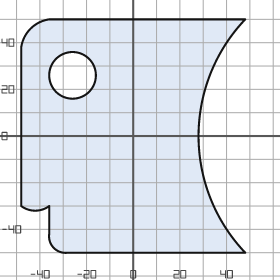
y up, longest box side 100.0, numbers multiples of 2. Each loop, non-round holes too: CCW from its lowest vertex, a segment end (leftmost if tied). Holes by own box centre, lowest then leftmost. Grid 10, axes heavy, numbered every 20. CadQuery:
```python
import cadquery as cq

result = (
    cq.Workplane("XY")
    .moveTo(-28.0, -50.0)
    .lineTo(48.0, -50.0)
    .threePointArc((28.0, 0.0), (48.0, 50.0))
    .lineTo(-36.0, 50.0)
    .threePointArc((-44.0, 46.0), (-48.0, 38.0))
    .lineTo(-48.0, -30.0)
    .threePointArc((-42.0, -32.0), (-36.0, -30.0))
    .lineTo(-36.0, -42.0)
    .threePointArc((-34.0, -48.0), (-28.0, -50.0))
    .close()
    .moveTo(-26.0, 26.0)
    .circle(10.0)
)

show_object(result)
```